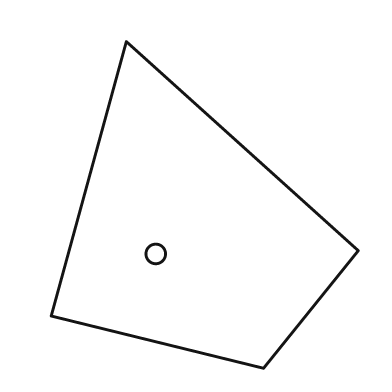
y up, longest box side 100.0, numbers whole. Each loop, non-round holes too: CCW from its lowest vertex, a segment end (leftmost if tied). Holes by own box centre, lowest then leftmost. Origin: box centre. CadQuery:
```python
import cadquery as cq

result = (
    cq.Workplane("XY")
    .moveTo(18.0, -50.0)
    .lineTo(47.0, -14.0)
    .lineTo(-24.0, 50.0)
    .lineTo(-47.0, -34.0)
    .close()
    .moveTo(-15.0, -15.0)
    .circle(3.0)
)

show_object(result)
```